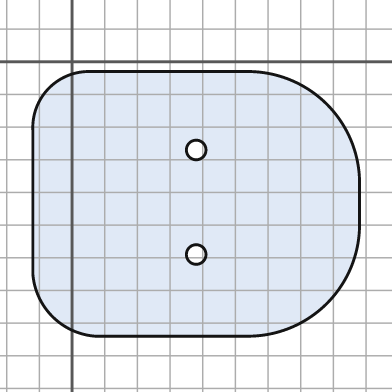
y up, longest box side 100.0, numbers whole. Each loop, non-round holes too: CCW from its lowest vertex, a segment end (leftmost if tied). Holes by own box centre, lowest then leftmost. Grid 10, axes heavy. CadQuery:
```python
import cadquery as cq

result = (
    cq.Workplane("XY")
    .moveTo(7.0, -84.0)
    .lineTo(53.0, -84.0)
    .threePointArc((78.0, -74.0), (88.0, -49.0))
    .lineTo(88.0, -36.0)
    .threePointArc((78.0, -13.0), (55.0, -3.0))
    .lineTo(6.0, -3.0)
    .threePointArc((-7.0, -8.0), (-12.0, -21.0))
    .lineTo(-12.0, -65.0)
    .threePointArc((-6.0, -78.0), (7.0, -84.0))
    .close()
    .moveTo(38.0, -59.0)
    .circle(3.0)
    .moveTo(38.0, -27.0)
    .circle(3.0)
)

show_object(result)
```